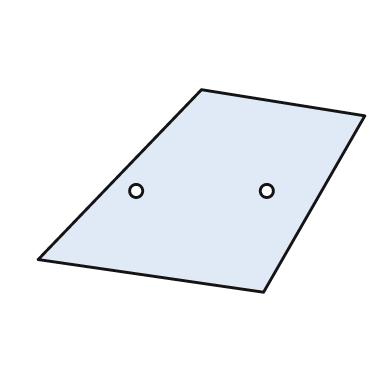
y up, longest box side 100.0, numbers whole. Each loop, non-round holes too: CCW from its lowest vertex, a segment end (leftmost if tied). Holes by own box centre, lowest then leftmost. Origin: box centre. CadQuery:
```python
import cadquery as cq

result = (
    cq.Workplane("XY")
    .moveTo(19.0, -31.0)
    .lineTo(50.0, 23.0)
    .lineTo(0.0, 31.0)
    .lineTo(-50.0, -21.0)
    .close()
    .moveTo(-20.0, 0.0)
    .circle(2.0)
    .moveTo(20.0, 0.0)
    .circle(2.0)
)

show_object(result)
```